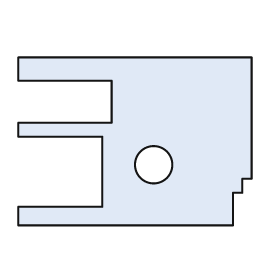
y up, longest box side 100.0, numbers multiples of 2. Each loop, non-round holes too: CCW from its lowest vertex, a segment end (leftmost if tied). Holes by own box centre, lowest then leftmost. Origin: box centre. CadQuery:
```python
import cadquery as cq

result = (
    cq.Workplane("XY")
    .moveTo(-50.0, -36.0)
    .lineTo(42.0, -36.0)
    .lineTo(42.0, -22.0)
    .lineTo(46.0, -22.0)
    .lineTo(46.0, -16.0)
    .lineTo(50.0, -16.0)
    .lineTo(50.0, 36.0)
    .lineTo(-50.0, 36.0)
    .lineTo(-50.0, 26.0)
    .lineTo(-10.0, 26.0)
    .lineTo(-10.0, 8.0)
    .lineTo(-50.0, 8.0)
    .lineTo(-50.0, 2.0)
    .lineTo(-14.0, 2.0)
    .lineTo(-14.0, -28.0)
    .lineTo(-50.0, -28.0)
    .close()
    .moveTo(8.0, -10.0)
    .circle(8.0)
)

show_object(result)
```